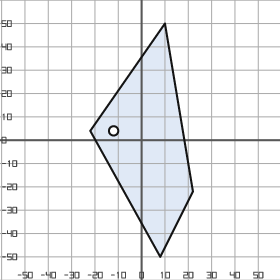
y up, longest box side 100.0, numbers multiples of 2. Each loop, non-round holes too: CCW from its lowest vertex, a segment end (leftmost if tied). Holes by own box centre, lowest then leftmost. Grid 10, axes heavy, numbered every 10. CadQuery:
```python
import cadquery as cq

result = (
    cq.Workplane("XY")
    .moveTo(8.0, -50.0)
    .lineTo(22.0, -22.0)
    .lineTo(10.0, 50.0)
    .lineTo(-22.0, 4.0)
    .close()
    .moveTo(-12.0, 4.0)
    .circle(2.0)
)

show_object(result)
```